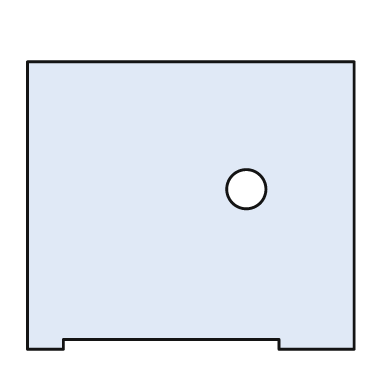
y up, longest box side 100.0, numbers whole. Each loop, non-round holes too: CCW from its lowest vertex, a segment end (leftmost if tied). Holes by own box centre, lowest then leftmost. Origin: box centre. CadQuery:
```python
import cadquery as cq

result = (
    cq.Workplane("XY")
    .moveTo(-50.0, -44.0)
    .lineTo(-39.0, -44.0)
    .lineTo(-39.0, -41.0)
    .lineTo(27.0, -41.0)
    .lineTo(27.0, -44.0)
    .lineTo(50.0, -44.0)
    .lineTo(50.0, 44.0)
    .lineTo(-50.0, 44.0)
    .close()
    .moveTo(17.0, 5.0)
    .circle(6.0)
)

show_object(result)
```